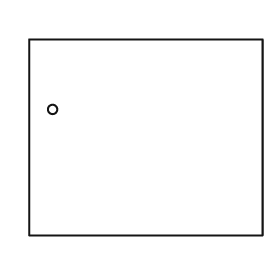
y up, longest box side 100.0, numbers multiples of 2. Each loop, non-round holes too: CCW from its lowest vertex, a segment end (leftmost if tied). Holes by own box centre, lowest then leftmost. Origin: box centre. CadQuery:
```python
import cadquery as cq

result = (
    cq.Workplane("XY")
    .moveTo(-50.0, -42.0)
    .lineTo(50.0, -42.0)
    .lineTo(50.0, 42.0)
    .lineTo(-50.0, 42.0)
    .close()
    .moveTo(-40.0, 12.0)
    .circle(2.0)
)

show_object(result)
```